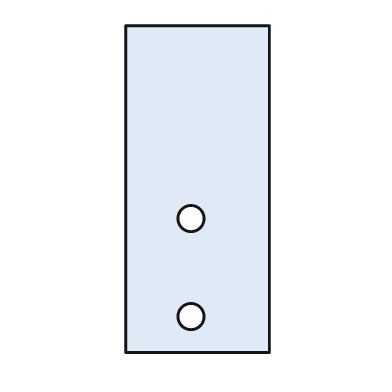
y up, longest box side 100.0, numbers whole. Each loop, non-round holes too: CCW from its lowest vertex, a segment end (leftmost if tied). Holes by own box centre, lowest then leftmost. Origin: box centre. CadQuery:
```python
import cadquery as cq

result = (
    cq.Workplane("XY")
    .moveTo(-22.0, -50.0)
    .lineTo(22.0, -50.0)
    .lineTo(22.0, 50.0)
    .lineTo(-22.0, 50.0)
    .close()
    .moveTo(-2.0, -39.0)
    .circle(4.0)
    .moveTo(-2.0, -9.0)
    .circle(4.0)
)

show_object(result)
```